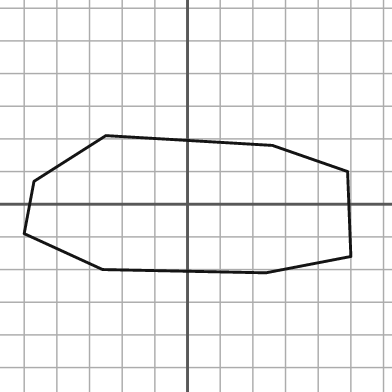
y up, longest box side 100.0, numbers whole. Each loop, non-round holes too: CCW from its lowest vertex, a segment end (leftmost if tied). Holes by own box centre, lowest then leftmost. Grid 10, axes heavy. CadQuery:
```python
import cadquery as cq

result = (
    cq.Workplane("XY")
    .moveTo(24.0, -21.0)
    .lineTo(50.0, -16.0)
    .lineTo(49.0, 10.0)
    .lineTo(26.0, 18.0)
    .lineTo(-25.0, 21.0)
    .lineTo(-47.0, 7.0)
    .lineTo(-50.0, -9.0)
    .lineTo(-26.0, -20.0)
    .close()
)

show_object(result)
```